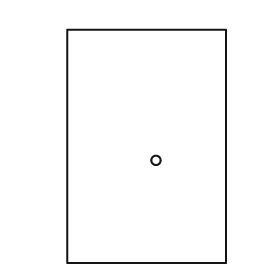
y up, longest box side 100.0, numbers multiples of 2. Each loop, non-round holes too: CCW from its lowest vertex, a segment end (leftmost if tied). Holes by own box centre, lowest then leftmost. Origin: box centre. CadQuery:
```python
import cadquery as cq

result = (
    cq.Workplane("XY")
    .moveTo(-34.0, -50.0)
    .lineTo(34.0, -50.0)
    .lineTo(34.0, 50.0)
    .lineTo(-34.0, 50.0)
    .close()
    .moveTo(4.0, -6.0)
    .circle(2.0)
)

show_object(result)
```